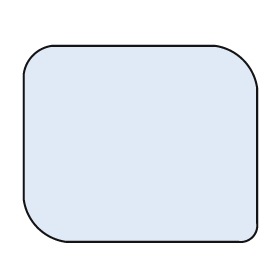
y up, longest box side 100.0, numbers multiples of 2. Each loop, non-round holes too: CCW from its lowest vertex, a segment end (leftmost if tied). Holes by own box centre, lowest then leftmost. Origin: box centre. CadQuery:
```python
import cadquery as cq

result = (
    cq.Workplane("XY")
    .moveTo(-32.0, -42.0)
    .lineTo(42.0, -42.0)
    .threePointArc((48.0, -40.0), (50.0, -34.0))
    .lineTo(50.0, 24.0)
    .threePointArc((44.0, 36.0), (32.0, 42.0))
    .lineTo(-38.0, 42.0)
    .threePointArc((-46.0, 38.0), (-50.0, 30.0))
    .lineTo(-50.0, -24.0)
    .threePointArc((-44.0, -36.0), (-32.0, -42.0))
    .close()
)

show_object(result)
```